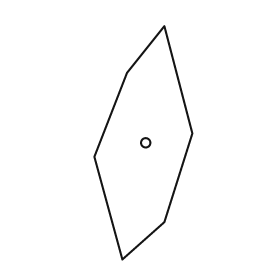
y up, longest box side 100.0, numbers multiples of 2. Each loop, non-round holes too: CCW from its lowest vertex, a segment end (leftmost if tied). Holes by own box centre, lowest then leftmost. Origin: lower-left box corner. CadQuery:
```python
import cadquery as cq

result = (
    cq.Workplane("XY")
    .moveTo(12.0, 0.0)
    .lineTo(30.0, 16.0)
    .lineTo(42.0, 54.0)
    .lineTo(30.0, 100.0)
    .lineTo(14.0, 80.0)
    .lineTo(0.0, 44.0)
    .close()
    .moveTo(22.0, 50.0)
    .circle(2.0)
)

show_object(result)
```